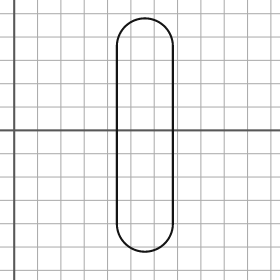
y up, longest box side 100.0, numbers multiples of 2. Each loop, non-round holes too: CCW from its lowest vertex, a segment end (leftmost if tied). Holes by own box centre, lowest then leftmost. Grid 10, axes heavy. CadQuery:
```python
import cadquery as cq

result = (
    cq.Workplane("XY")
    .moveTo(44.0, -40.0)
    .threePointArc((56.0, -52.0), (68.0, -40.0))
    .lineTo(68.0, 36.0)
    .threePointArc((56.0, 48.0), (44.0, 36.0))
    .close()
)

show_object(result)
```